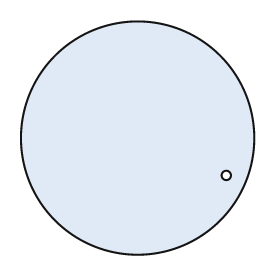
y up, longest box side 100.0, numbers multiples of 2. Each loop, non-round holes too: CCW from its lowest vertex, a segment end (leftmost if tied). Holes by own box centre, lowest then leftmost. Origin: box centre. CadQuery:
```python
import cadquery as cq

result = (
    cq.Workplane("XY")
    .moveTo(0.0, 0.0)
    .circle(50.0)
    .moveTo(38.0, -16.0)
    .circle(2.0)
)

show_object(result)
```